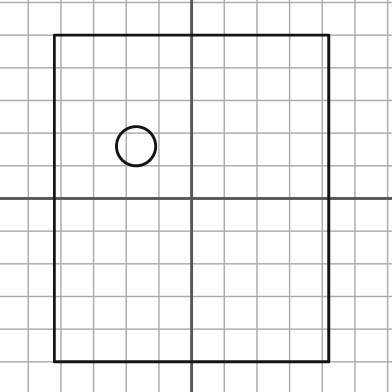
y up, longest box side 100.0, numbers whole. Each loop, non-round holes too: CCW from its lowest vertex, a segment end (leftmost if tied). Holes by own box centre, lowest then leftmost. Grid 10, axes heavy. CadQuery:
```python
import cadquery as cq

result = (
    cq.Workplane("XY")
    .moveTo(-42.0, -50.0)
    .lineTo(42.0, -50.0)
    .lineTo(42.0, 50.0)
    .lineTo(-42.0, 50.0)
    .close()
    .moveTo(-17.0, 16.0)
    .circle(6.0)
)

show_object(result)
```